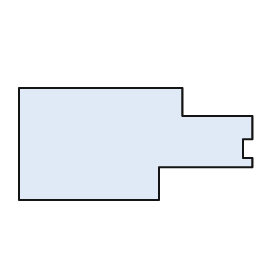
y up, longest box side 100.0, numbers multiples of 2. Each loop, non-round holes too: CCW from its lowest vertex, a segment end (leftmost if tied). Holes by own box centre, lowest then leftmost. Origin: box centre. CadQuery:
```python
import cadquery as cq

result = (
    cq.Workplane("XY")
    .moveTo(-50.0, -24.0)
    .lineTo(10.0, -24.0)
    .lineTo(10.0, -10.0)
    .lineTo(50.0, -10.0)
    .lineTo(50.0, -6.0)
    .lineTo(46.0, -6.0)
    .lineTo(46.0, 2.0)
    .lineTo(50.0, 2.0)
    .lineTo(50.0, 12.0)
    .lineTo(20.0, 12.0)
    .lineTo(20.0, 24.0)
    .lineTo(-50.0, 24.0)
    .close()
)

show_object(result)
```